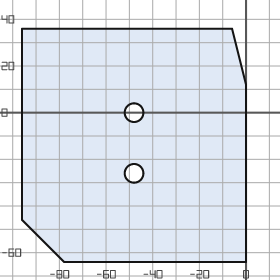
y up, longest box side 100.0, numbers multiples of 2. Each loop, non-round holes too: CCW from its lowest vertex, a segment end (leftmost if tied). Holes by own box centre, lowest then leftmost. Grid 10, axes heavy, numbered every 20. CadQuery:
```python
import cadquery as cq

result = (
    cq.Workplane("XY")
    .moveTo(-78.0, -64.0)
    .lineTo(0.0, -64.0)
    .lineTo(0.0, 12.0)
    .lineTo(-6.0, 36.0)
    .lineTo(-96.0, 36.0)
    .lineTo(-96.0, -46.0)
    .close()
    .moveTo(-48.0, -26.0)
    .circle(4.0)
    .moveTo(-48.0, 0.0)
    .circle(4.0)
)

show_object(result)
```